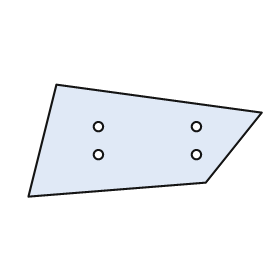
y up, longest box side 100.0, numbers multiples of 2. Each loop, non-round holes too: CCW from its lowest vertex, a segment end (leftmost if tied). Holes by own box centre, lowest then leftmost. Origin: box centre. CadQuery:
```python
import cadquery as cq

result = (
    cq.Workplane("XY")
    .moveTo(-50.0, -24.0)
    .lineTo(26.0, -18.0)
    .lineTo(50.0, 12.0)
    .lineTo(-38.0, 24.0)
    .close()
    .moveTo(-20.0, -6.0)
    .circle(2.0)
    .moveTo(22.0, -6.0)
    .circle(2.0)
    .moveTo(-20.0, 6.0)
    .circle(2.0)
    .moveTo(22.0, 6.0)
    .circle(2.0)
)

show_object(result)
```